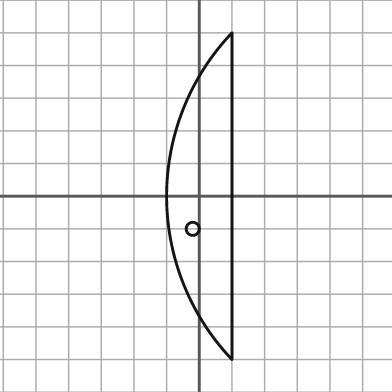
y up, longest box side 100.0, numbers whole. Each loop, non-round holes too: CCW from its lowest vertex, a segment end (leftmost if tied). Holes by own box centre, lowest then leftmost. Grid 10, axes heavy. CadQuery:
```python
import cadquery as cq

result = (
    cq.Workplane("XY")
    .moveTo(10.0, -50.0)
    .lineTo(10.0, 50.0)
    .threePointArc((-10.0, 0.0), (10.0, -50.0))
    .close()
    .moveTo(-2.0, -10.0)
    .circle(2.0)
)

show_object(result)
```